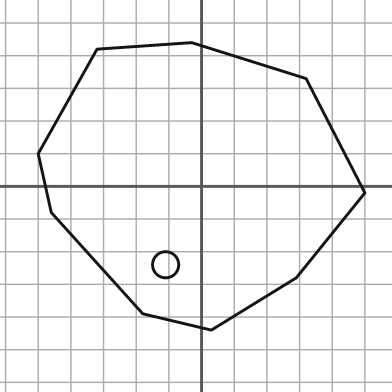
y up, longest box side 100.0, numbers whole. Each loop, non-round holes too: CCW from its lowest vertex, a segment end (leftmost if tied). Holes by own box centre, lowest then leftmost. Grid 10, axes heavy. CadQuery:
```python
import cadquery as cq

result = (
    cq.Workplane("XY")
    .moveTo(3.0, -44.0)
    .lineTo(29.0, -28.0)
    .lineTo(50.0, -2.0)
    .lineTo(32.0, 33.0)
    .lineTo(-3.0, 44.0)
    .lineTo(-32.0, 42.0)
    .lineTo(-50.0, 10.0)
    .lineTo(-46.0, -8.0)
    .lineTo(-18.0, -39.0)
    .close()
    .moveTo(-11.0, -24.0)
    .circle(4.0)
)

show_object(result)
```